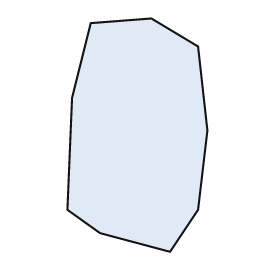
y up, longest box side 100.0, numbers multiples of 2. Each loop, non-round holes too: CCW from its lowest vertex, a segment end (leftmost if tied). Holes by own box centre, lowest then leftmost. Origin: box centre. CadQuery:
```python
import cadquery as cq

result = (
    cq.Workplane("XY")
    .moveTo(14.0, -50.0)
    .lineTo(26.0, -32.0)
    .lineTo(30.0, 2.0)
    .lineTo(26.0, 38.0)
    .lineTo(6.0, 50.0)
    .lineTo(-20.0, 48.0)
    .lineTo(-28.0, 16.0)
    .lineTo(-30.0, -32.0)
    .lineTo(-16.0, -42.0)
    .close()
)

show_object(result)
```